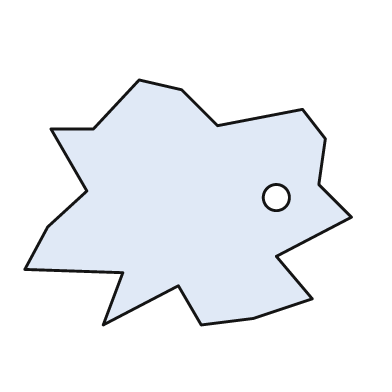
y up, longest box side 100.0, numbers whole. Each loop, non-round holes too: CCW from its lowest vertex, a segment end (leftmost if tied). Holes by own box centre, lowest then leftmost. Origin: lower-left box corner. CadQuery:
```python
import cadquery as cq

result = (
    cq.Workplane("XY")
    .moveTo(24.0, 0.0)
    .lineTo(47.0, 12.0)
    .lineTo(54.0, 0.0)
    .lineTo(70.0, 2.0)
    .lineTo(88.0, 8.0)
    .lineTo(77.0, 21.0)
    .lineTo(100.0, 33.0)
    .lineTo(90.0, 43.0)
    .lineTo(92.0, 57.0)
    .lineTo(85.0, 66.0)
    .lineTo(59.0, 61.0)
    .lineTo(48.0, 72.0)
    .lineTo(35.0, 75.0)
    .lineTo(21.0, 60.0)
    .lineTo(8.0, 60.0)
    .lineTo(19.0, 41.0)
    .lineTo(7.0, 30.0)
    .lineTo(0.0, 17.0)
    .lineTo(30.0, 16.0)
    .close()
    .moveTo(77.0, 39.0)
    .circle(4.0)
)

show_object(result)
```